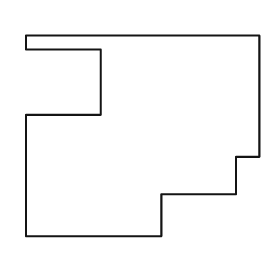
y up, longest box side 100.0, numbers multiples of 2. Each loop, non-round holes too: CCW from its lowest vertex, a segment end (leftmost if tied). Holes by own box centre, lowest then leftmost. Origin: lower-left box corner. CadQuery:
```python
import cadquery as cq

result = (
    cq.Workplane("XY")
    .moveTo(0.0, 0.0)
    .lineTo(58.0, 0.0)
    .lineTo(58.0, 18.0)
    .lineTo(90.0, 18.0)
    .lineTo(90.0, 34.0)
    .lineTo(100.0, 34.0)
    .lineTo(100.0, 86.0)
    .lineTo(0.0, 86.0)
    .lineTo(0.0, 80.0)
    .lineTo(32.0, 80.0)
    .lineTo(32.0, 52.0)
    .lineTo(0.0, 52.0)
    .close()
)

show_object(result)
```